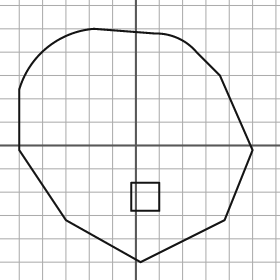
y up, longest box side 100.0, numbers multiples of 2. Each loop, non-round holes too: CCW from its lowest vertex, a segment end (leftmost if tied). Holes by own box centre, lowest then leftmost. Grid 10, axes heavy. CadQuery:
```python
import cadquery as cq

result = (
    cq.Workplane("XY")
    .moveTo(2.0, -50.0)
    .lineTo(38.0, -32.0)
    .lineTo(50.0, -2.0)
    .lineTo(36.0, 30.0)
    .lineTo(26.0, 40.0)
    .threePointArc((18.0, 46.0), (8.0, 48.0))
    .lineTo(-18.0, 50.0)
    .threePointArc((-38.0, 42.0), (-50.0, 24.0))
    .lineTo(-50.0, -2.0)
    .lineTo(-30.0, -32.0)
    .close()
    .moveTo(-2.0, -28.0)
    .lineTo(10.0, -28.0)
    .lineTo(10.0, -16.0)
    .lineTo(-2.0, -16.0)
    .close()
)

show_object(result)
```